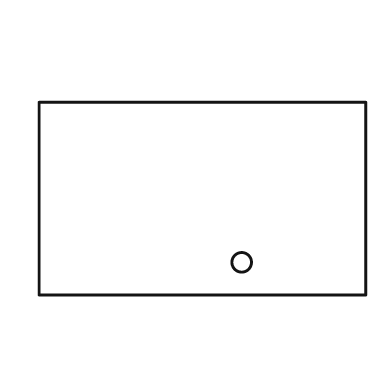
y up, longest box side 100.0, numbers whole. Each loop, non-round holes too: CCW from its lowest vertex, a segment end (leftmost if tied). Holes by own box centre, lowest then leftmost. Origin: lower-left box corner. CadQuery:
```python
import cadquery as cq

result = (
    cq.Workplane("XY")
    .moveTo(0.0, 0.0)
    .lineTo(100.0, 0.0)
    .lineTo(100.0, 59.0)
    .lineTo(0.0, 59.0)
    .close()
    .moveTo(62.0, 10.0)
    .circle(3.0)
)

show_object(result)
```